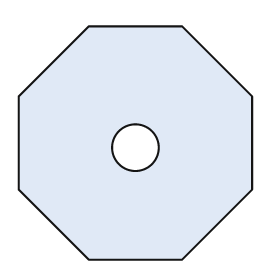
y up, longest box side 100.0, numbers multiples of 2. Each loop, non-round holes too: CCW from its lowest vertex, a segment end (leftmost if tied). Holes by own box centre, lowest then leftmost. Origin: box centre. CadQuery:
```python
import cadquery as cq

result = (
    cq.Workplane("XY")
    .moveTo(-20.0, -50.0)
    .lineTo(20.0, -50.0)
    .lineTo(50.0, -20.0)
    .lineTo(50.0, 20.0)
    .lineTo(20.0, 50.0)
    .lineTo(-20.0, 50.0)
    .lineTo(-50.0, 20.0)
    .lineTo(-50.0, -20.0)
    .close()
    .moveTo(0.0, -2.0)
    .circle(10.0)
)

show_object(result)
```